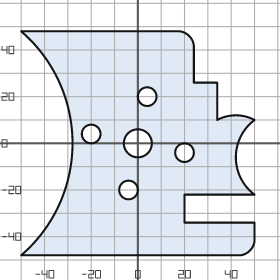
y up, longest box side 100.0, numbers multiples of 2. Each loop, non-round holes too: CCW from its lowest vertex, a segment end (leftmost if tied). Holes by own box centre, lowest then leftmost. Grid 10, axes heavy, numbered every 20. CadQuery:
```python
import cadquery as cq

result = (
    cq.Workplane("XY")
    .moveTo(-50.0, -48.0)
    .lineTo(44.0, -48.0)
    .threePointArc((48.0, -46.0), (50.0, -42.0))
    .lineTo(50.0, -34.0)
    .lineTo(20.0, -34.0)
    .lineTo(20.0, -22.0)
    .lineTo(50.0, -22.0)
    .threePointArc((42.0, -6.0), (50.0, 10.0))
    .threePointArc((42.0, 12.0), (34.0, 10.0))
    .lineTo(34.0, 26.0)
    .lineTo(24.0, 26.0)
    .lineTo(24.0, 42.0)
    .threePointArc((22.0, 46.0), (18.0, 48.0))
    .lineTo(-50.0, 48.0)
    .threePointArc((-28.0, 0.0), (-50.0, -48.0))
    .close()
    .moveTo(-4.0, -20.0)
    .circle(4.0)
    .moveTo(20.0, -4.0)
    .circle(4.0)
    .moveTo(0.0, 0.0)
    .circle(6.0)
    .moveTo(-20.0, 4.0)
    .circle(4.0)
    .moveTo(4.0, 20.0)
    .circle(4.0)
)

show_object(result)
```